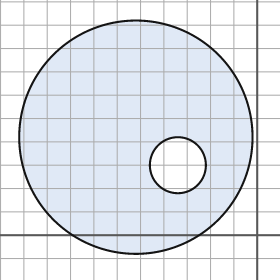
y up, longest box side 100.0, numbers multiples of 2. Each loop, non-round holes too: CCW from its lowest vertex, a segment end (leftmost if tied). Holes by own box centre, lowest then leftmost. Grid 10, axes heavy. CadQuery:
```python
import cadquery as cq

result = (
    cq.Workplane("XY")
    .moveTo(-52.0, 42.0)
    .circle(50.0)
    .moveTo(-34.0, 30.0)
    .circle(12.0)
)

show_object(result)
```